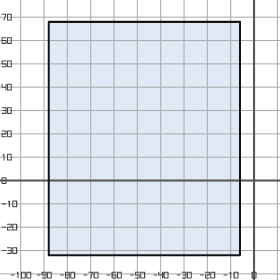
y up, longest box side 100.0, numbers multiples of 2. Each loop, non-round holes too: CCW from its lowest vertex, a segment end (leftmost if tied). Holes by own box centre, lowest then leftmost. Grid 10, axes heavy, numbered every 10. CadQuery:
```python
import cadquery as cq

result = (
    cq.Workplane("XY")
    .moveTo(-88.0, -32.0)
    .lineTo(-6.0, -32.0)
    .lineTo(-6.0, 68.0)
    .lineTo(-88.0, 68.0)
    .close()
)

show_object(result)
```